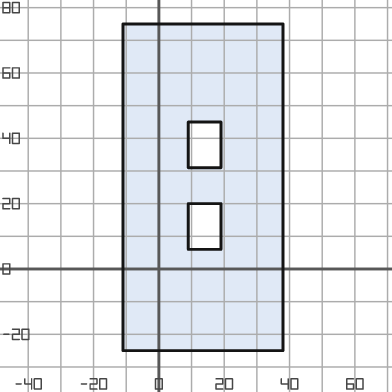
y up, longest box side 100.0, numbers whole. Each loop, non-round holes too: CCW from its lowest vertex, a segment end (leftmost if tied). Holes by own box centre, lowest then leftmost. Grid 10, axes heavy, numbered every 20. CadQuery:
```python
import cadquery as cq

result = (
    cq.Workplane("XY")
    .moveTo(-11.0, -25.0)
    .lineTo(38.0, -25.0)
    .lineTo(38.0, 75.0)
    .lineTo(-11.0, 75.0)
    .close()
    .moveTo(9.0, 6.0)
    .lineTo(19.0, 6.0)
    .lineTo(19.0, 20.0)
    .lineTo(9.0, 20.0)
    .close()
    .moveTo(9.0, 31.0)
    .lineTo(19.0, 31.0)
    .lineTo(19.0, 45.0)
    .lineTo(9.0, 45.0)
    .close()
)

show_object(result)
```